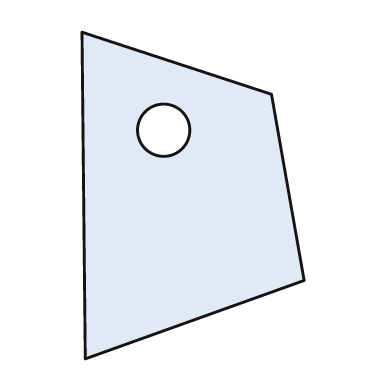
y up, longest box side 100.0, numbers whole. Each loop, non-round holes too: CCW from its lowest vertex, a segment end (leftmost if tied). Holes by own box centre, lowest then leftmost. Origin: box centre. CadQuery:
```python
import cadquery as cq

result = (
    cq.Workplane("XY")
    .moveTo(-33.0, -50.0)
    .lineTo(34.0, -26.0)
    .lineTo(24.0, 31.0)
    .lineTo(-34.0, 50.0)
    .close()
    .moveTo(-9.0, 20.0)
    .circle(8.0)
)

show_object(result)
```